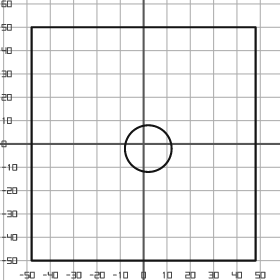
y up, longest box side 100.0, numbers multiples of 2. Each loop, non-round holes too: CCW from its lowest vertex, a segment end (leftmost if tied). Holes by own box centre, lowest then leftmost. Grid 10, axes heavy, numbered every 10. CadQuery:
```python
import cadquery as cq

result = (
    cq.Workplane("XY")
    .moveTo(-48.0, -50.0)
    .lineTo(48.0, -50.0)
    .lineTo(48.0, 50.0)
    .lineTo(-48.0, 50.0)
    .close()
    .moveTo(2.0, -2.0)
    .circle(10.0)
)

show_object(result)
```